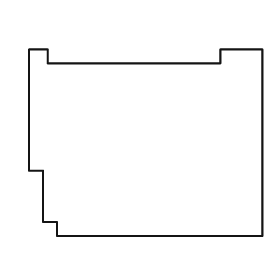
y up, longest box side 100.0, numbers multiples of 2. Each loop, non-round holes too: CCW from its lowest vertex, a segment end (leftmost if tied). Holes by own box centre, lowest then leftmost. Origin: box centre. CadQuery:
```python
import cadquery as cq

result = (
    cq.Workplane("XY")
    .moveTo(-38.0, -40.0)
    .lineTo(50.0, -40.0)
    .lineTo(50.0, 40.0)
    .lineTo(32.0, 40.0)
    .lineTo(32.0, 34.0)
    .lineTo(-42.0, 34.0)
    .lineTo(-42.0, 40.0)
    .lineTo(-50.0, 40.0)
    .lineTo(-50.0, -12.0)
    .lineTo(-44.0, -12.0)
    .lineTo(-44.0, -34.0)
    .lineTo(-38.0, -34.0)
    .close()
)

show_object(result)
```